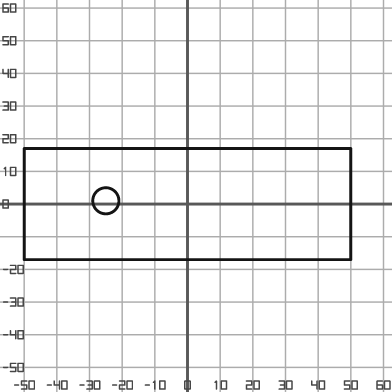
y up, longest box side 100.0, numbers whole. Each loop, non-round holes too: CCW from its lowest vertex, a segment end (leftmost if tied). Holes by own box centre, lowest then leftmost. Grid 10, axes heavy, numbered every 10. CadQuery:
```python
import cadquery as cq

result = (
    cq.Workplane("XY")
    .moveTo(-50.0, -17.0)
    .lineTo(50.0, -17.0)
    .lineTo(50.0, 17.0)
    .lineTo(-50.0, 17.0)
    .close()
    .moveTo(-25.0, 1.0)
    .circle(4.0)
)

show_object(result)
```